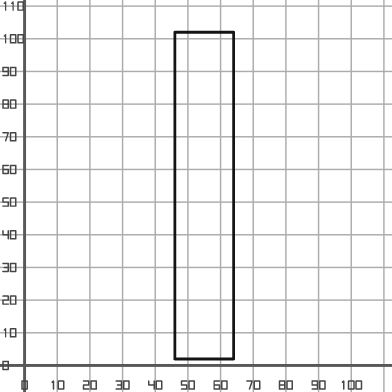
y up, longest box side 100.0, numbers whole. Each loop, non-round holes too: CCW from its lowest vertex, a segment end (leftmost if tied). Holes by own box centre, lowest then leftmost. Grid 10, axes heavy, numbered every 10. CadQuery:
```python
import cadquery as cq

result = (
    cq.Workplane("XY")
    .moveTo(46.0, 2.0)
    .lineTo(64.0, 2.0)
    .lineTo(64.0, 102.0)
    .lineTo(46.0, 102.0)
    .close()
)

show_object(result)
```